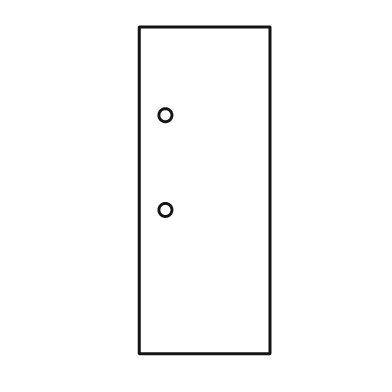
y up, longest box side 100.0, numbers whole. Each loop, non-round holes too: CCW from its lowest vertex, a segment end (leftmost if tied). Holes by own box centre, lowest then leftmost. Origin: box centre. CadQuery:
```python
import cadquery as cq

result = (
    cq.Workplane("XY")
    .moveTo(-20.0, -50.0)
    .lineTo(20.0, -50.0)
    .lineTo(20.0, 50.0)
    .lineTo(-20.0, 50.0)
    .close()
    .moveTo(-12.0, -6.0)
    .circle(2.0)
    .moveTo(-12.0, 23.0)
    .circle(2.0)
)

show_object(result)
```